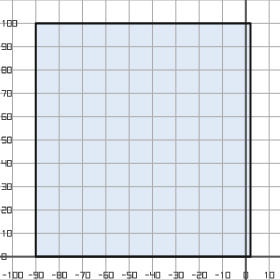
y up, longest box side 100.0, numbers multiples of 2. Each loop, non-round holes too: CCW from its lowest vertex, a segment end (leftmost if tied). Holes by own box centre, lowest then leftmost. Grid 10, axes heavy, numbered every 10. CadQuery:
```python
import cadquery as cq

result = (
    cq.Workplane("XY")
    .moveTo(-90.0, 0.0)
    .lineTo(2.0, 0.0)
    .lineTo(2.0, 100.0)
    .lineTo(-90.0, 100.0)
    .close()
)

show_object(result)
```